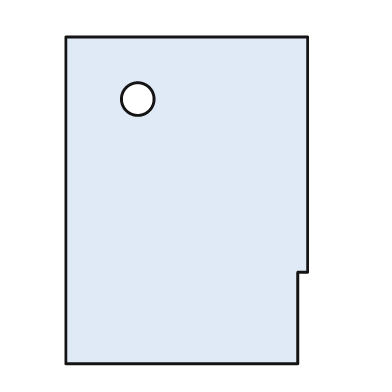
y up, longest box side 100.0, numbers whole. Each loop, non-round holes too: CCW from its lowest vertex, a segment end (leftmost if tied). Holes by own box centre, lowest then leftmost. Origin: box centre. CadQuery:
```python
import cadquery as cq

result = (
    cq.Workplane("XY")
    .moveTo(-37.0, -50.0)
    .lineTo(34.0, -50.0)
    .lineTo(34.0, -22.0)
    .lineTo(37.0, -22.0)
    .lineTo(37.0, 50.0)
    .lineTo(-37.0, 50.0)
    .close()
    .moveTo(-15.0, 31.0)
    .circle(5.0)
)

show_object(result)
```